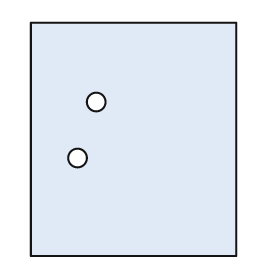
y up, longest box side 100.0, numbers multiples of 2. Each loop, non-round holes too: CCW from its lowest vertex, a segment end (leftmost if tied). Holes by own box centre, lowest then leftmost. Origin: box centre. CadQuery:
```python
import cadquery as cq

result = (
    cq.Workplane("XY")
    .moveTo(-44.0, -50.0)
    .lineTo(44.0, -50.0)
    .lineTo(44.0, 50.0)
    .lineTo(-44.0, 50.0)
    .close()
    .moveTo(-24.0, -8.0)
    .circle(4.0)
    .moveTo(-16.0, 16.0)
    .circle(4.0)
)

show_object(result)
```